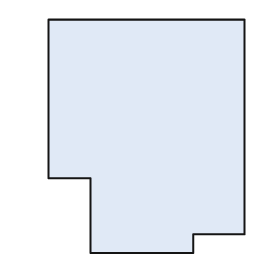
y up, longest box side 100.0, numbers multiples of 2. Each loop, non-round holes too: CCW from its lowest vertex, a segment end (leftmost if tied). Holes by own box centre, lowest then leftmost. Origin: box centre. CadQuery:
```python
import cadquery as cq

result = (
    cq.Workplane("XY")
    .moveTo(-24.0, -50.0)
    .lineTo(20.0, -50.0)
    .lineTo(20.0, -42.0)
    .lineTo(42.0, -42.0)
    .lineTo(42.0, 50.0)
    .lineTo(-42.0, 50.0)
    .lineTo(-42.0, -18.0)
    .lineTo(-24.0, -18.0)
    .close()
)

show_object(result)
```